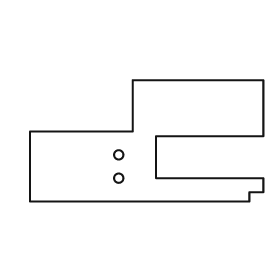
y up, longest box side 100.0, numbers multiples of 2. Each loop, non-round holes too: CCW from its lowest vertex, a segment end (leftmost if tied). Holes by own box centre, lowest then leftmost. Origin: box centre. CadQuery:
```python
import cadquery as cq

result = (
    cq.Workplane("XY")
    .moveTo(-50.0, -26.0)
    .lineTo(44.0, -26.0)
    .lineTo(44.0, -22.0)
    .lineTo(50.0, -22.0)
    .lineTo(50.0, -16.0)
    .lineTo(4.0, -16.0)
    .lineTo(4.0, 2.0)
    .lineTo(50.0, 2.0)
    .lineTo(50.0, 26.0)
    .lineTo(-6.0, 26.0)
    .lineTo(-6.0, 4.0)
    .lineTo(-50.0, 4.0)
    .close()
    .moveTo(-12.0, -16.0)
    .circle(2.0)
    .moveTo(-12.0, -6.0)
    .circle(2.0)
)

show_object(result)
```